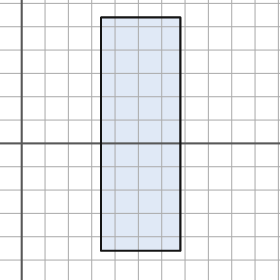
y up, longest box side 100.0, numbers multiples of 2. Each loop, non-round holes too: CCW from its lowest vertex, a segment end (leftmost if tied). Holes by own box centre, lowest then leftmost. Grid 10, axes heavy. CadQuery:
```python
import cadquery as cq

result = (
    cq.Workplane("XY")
    .moveTo(34.0, -46.0)
    .lineTo(68.0, -46.0)
    .lineTo(68.0, 54.0)
    .lineTo(34.0, 54.0)
    .close()
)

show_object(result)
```